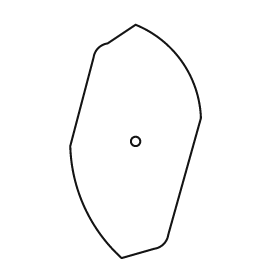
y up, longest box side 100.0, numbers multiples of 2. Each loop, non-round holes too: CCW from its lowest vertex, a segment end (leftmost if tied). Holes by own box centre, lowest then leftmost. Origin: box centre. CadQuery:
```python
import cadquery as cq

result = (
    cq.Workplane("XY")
    .moveTo(-6.0, -50.0)
    .lineTo(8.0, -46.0)
    .threePointArc((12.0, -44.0), (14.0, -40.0))
    .lineTo(28.0, 10.0)
    .threePointArc((20.0, 34.0), (0.0, 50.0))
    .lineTo(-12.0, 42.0)
    .threePointArc((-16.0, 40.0), (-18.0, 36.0))
    .lineTo(-28.0, -2.0)
    .threePointArc((-22.0, -28.0), (-6.0, -50.0))
    .close()
    .moveTo(0.0, 0.0)
    .circle(2.0)
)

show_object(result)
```